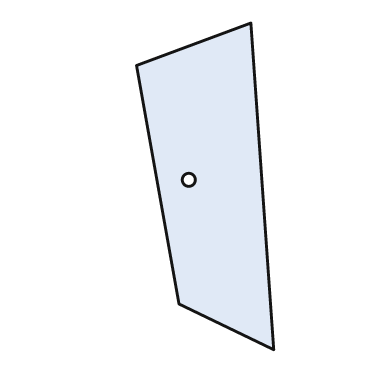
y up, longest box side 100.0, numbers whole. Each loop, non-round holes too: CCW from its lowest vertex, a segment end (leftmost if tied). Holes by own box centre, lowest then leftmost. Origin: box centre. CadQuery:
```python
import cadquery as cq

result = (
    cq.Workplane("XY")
    .moveTo(21.0, -50.0)
    .lineTo(14.0, 50.0)
    .lineTo(-21.0, 37.0)
    .lineTo(-8.0, -36.0)
    .close()
    .moveTo(-5.0, 2.0)
    .circle(2.0)
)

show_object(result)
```